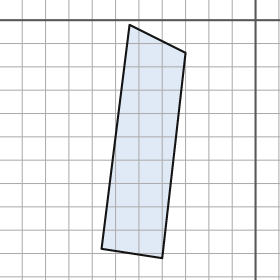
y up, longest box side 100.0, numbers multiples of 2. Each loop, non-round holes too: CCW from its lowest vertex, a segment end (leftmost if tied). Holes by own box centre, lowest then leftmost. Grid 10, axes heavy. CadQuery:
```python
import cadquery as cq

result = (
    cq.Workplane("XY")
    .moveTo(-40.0, -102.0)
    .lineTo(-30.0, -14.0)
    .lineTo(-54.0, -2.0)
    .lineTo(-66.0, -98.0)
    .close()
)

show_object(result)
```